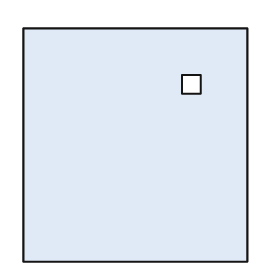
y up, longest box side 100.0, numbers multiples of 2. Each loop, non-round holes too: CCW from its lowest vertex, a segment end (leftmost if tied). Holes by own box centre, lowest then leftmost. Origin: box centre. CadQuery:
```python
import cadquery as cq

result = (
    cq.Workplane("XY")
    .moveTo(-48.0, -50.0)
    .lineTo(48.0, -50.0)
    .lineTo(48.0, 50.0)
    .lineTo(-48.0, 50.0)
    .close()
    .moveTo(20.0, 22.0)
    .lineTo(28.0, 22.0)
    .lineTo(28.0, 30.0)
    .lineTo(20.0, 30.0)
    .close()
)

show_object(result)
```